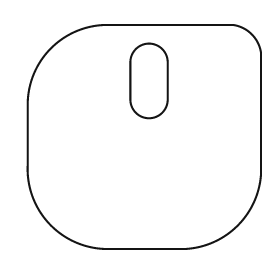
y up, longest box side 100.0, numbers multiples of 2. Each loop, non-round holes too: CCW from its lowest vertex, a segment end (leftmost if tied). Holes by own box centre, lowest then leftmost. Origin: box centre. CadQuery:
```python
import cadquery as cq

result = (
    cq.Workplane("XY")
    .moveTo(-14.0, -48.0)
    .lineTo(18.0, -48.0)
    .threePointArc((40.0, -38.0), (50.0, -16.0))
    .lineTo(50.0, 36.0)
    .threePointArc((46.0, 44.0), (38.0, 48.0))
    .lineTo(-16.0, 48.0)
    .threePointArc((-40.0, 38.0), (-50.0, 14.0))
    .lineTo(-50.0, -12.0)
    .threePointArc((-40.0, -38.0), (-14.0, -48.0))
    .close()
    .moveTo(-6.0, 16.0)
    .threePointArc((2.0, 8.0), (10.0, 16.0))
    .lineTo(10.0, 32.0)
    .threePointArc((2.0, 40.0), (-6.0, 32.0))
    .close()
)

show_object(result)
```